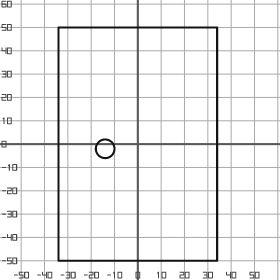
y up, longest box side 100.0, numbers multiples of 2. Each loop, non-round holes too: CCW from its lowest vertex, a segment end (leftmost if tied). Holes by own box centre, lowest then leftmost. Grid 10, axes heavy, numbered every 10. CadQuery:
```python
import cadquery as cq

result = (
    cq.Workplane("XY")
    .moveTo(-34.0, -50.0)
    .lineTo(34.0, -50.0)
    .lineTo(34.0, 50.0)
    .lineTo(-34.0, 50.0)
    .close()
    .moveTo(-14.0, -2.0)
    .circle(4.0)
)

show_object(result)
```